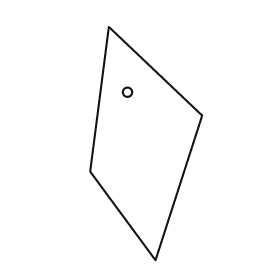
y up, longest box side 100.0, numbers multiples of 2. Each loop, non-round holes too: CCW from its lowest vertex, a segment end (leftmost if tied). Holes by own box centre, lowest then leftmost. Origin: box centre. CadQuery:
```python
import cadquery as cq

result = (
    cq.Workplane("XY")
    .moveTo(4.0, -50.0)
    .lineTo(24.0, 12.0)
    .lineTo(-16.0, 50.0)
    .lineTo(-24.0, -12.0)
    .close()
    .moveTo(-8.0, 22.0)
    .circle(2.0)
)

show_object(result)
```